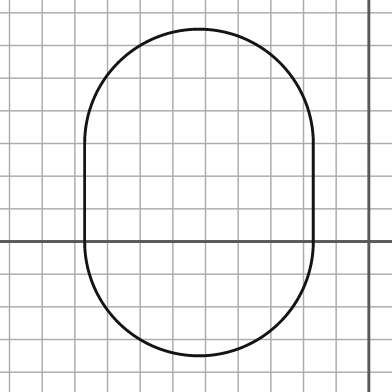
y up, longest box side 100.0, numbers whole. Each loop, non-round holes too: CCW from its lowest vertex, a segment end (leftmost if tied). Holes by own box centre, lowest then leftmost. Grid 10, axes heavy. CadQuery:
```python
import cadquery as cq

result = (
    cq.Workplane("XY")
    .moveTo(-87.0, 0.0)
    .threePointArc((-52.0, -35.0), (-17.0, 0.0))
    .lineTo(-17.0, 30.0)
    .threePointArc((-52.0, 65.0), (-87.0, 30.0))
    .close()
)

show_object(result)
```